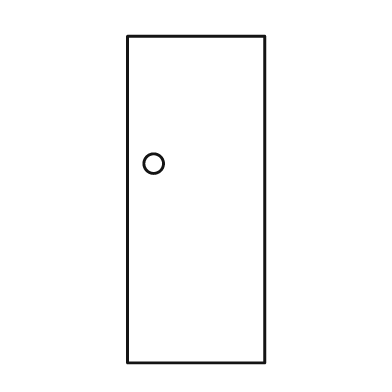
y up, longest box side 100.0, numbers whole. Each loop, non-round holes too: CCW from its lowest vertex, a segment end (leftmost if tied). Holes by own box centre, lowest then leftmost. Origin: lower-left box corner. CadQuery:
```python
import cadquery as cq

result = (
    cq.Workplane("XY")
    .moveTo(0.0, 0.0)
    .lineTo(42.0, 0.0)
    .lineTo(42.0, 100.0)
    .lineTo(0.0, 100.0)
    .close()
    .moveTo(8.0, 61.0)
    .circle(3.0)
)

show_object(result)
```